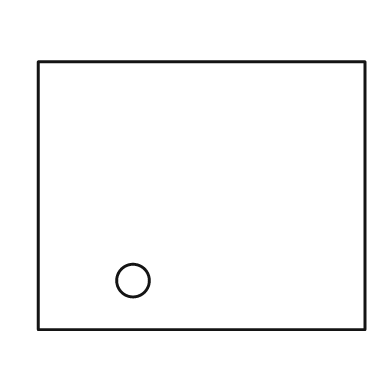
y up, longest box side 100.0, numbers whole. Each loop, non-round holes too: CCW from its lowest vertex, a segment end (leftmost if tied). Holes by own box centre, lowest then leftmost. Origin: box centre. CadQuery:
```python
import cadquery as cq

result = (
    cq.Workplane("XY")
    .moveTo(-50.0, -41.0)
    .lineTo(50.0, -41.0)
    .lineTo(50.0, 41.0)
    .lineTo(-50.0, 41.0)
    .close()
    .moveTo(-21.0, -26.0)
    .circle(5.0)
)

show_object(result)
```